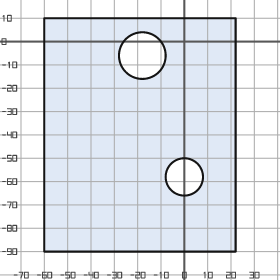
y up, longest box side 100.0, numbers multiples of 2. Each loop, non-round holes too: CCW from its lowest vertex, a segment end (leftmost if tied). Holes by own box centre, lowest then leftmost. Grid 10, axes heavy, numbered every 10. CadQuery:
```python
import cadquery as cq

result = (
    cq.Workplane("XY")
    .moveTo(-60.0, -90.0)
    .lineTo(22.0, -90.0)
    .lineTo(22.0, 10.0)
    .lineTo(-60.0, 10.0)
    .close()
    .moveTo(0.0, -58.0)
    .circle(8.0)
    .moveTo(-18.0, -6.0)
    .circle(10.0)
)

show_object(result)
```